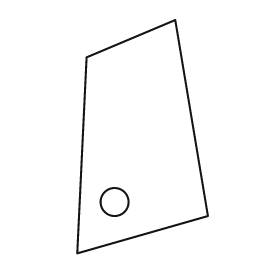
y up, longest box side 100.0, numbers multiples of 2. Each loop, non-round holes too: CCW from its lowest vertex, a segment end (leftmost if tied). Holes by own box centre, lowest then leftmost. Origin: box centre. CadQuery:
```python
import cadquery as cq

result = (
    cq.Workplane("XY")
    .moveTo(-28.0, -50.0)
    .lineTo(28.0, -34.0)
    .lineTo(14.0, 50.0)
    .lineTo(-24.0, 34.0)
    .close()
    .moveTo(-12.0, -28.0)
    .circle(6.0)
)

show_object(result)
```